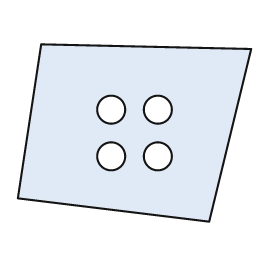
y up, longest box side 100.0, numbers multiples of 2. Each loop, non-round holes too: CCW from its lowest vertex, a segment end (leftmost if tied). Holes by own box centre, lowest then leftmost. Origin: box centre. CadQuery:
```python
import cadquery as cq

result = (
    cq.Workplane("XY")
    .moveTo(32.0, -38.0)
    .lineTo(50.0, 36.0)
    .lineTo(-40.0, 38.0)
    .lineTo(-50.0, -28.0)
    .close()
    .moveTo(-10.0, -10.0)
    .circle(6.0)
    .moveTo(10.0, -10.0)
    .circle(6.0)
    .moveTo(-10.0, 10.0)
    .circle(6.0)
    .moveTo(10.0, 10.0)
    .circle(6.0)
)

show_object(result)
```